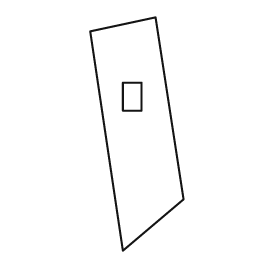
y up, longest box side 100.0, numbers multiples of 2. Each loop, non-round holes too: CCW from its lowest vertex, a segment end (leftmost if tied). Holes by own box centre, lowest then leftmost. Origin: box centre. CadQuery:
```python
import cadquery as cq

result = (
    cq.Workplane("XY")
    .moveTo(-6.0, -50.0)
    .lineTo(20.0, -28.0)
    .lineTo(8.0, 50.0)
    .lineTo(-20.0, 44.0)
    .close()
    .moveTo(-6.0, 10.0)
    .lineTo(2.0, 10.0)
    .lineTo(2.0, 22.0)
    .lineTo(-6.0, 22.0)
    .close()
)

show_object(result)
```